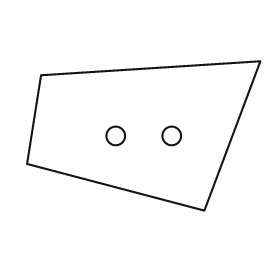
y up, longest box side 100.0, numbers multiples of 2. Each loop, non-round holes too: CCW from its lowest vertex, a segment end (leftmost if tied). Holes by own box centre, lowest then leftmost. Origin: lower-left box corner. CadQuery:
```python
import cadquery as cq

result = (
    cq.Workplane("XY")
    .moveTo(76.0, 0.0)
    .lineTo(100.0, 64.0)
    .lineTo(6.0, 58.0)
    .lineTo(0.0, 20.0)
    .close()
    .moveTo(38.0, 32.0)
    .circle(4.0)
    .moveTo(62.0, 32.0)
    .circle(4.0)
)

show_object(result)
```